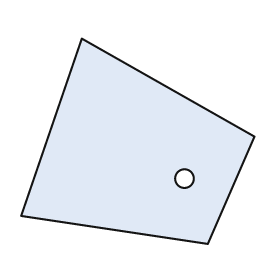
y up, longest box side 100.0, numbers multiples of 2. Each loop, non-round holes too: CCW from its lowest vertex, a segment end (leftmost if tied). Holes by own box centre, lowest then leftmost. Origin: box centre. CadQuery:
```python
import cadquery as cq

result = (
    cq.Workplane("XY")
    .moveTo(30.0, -44.0)
    .lineTo(50.0, 2.0)
    .lineTo(-24.0, 44.0)
    .lineTo(-50.0, -32.0)
    .close()
    .moveTo(20.0, -16.0)
    .circle(4.0)
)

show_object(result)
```